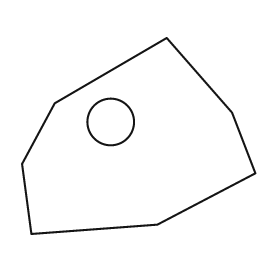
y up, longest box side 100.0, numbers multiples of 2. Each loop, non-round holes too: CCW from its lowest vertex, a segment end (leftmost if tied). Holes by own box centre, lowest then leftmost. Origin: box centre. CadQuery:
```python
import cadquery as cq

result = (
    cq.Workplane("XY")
    .moveTo(-46.0, -42.0)
    .lineTo(8.0, -38.0)
    .lineTo(50.0, -16.0)
    .lineTo(40.0, 10.0)
    .lineTo(12.0, 42.0)
    .lineTo(-36.0, 14.0)
    .lineTo(-50.0, -12.0)
    .close()
    .moveTo(-12.0, 6.0)
    .circle(10.0)
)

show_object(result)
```